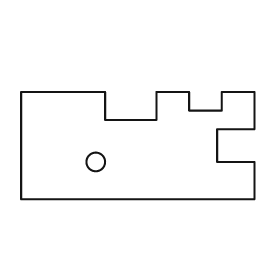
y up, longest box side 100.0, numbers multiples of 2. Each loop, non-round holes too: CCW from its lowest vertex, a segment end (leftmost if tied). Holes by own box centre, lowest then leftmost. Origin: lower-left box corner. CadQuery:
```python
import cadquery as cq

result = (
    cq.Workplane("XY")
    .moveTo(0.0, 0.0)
    .lineTo(100.0, 0.0)
    .lineTo(100.0, 16.0)
    .lineTo(84.0, 16.0)
    .lineTo(84.0, 30.0)
    .lineTo(100.0, 30.0)
    .lineTo(100.0, 46.0)
    .lineTo(86.0, 46.0)
    .lineTo(86.0, 38.0)
    .lineTo(72.0, 38.0)
    .lineTo(72.0, 46.0)
    .lineTo(58.0, 46.0)
    .lineTo(58.0, 34.0)
    .lineTo(36.0, 34.0)
    .lineTo(36.0, 46.0)
    .lineTo(0.0, 46.0)
    .close()
    .moveTo(32.0, 16.0)
    .circle(4.0)
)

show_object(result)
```